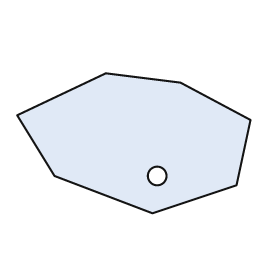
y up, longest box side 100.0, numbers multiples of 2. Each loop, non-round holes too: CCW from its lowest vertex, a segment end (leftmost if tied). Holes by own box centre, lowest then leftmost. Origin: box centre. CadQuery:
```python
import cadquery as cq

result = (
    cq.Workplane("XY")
    .moveTo(8.0, -30.0)
    .lineTo(44.0, -18.0)
    .lineTo(50.0, 10.0)
    .lineTo(20.0, 26.0)
    .lineTo(-12.0, 30.0)
    .lineTo(-50.0, 12.0)
    .lineTo(-34.0, -14.0)
    .close()
    .moveTo(10.0, -14.0)
    .circle(4.0)
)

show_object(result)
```